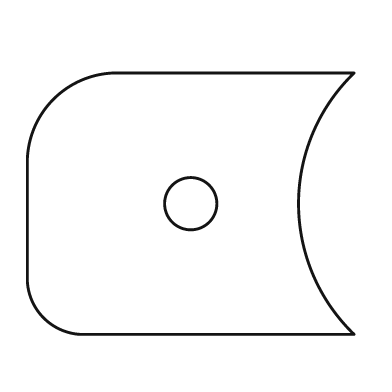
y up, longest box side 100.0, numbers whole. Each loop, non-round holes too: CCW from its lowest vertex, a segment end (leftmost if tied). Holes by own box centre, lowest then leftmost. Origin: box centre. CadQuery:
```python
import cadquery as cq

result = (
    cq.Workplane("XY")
    .moveTo(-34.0, -40.0)
    .lineTo(50.0, -40.0)
    .threePointArc((33.0, 0.0), (50.0, 40.0))
    .lineTo(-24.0, 40.0)
    .threePointArc((-42.0, 32.0), (-50.0, 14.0))
    .lineTo(-50.0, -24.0)
    .threePointArc((-45.0, -35.0), (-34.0, -40.0))
    .close()
    .moveTo(0.0, 0.0)
    .circle(8.0)
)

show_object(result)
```